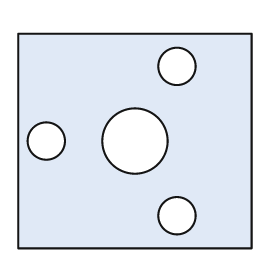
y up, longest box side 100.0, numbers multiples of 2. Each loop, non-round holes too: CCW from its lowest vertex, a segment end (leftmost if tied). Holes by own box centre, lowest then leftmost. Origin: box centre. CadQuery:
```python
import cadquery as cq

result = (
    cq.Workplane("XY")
    .moveTo(-50.0, -46.0)
    .lineTo(50.0, -46.0)
    .lineTo(50.0, 46.0)
    .lineTo(-50.0, 46.0)
    .close()
    .moveTo(18.0, -32.0)
    .circle(8.0)
    .moveTo(-38.0, 0.0)
    .circle(8.0)
    .moveTo(0.0, 0.0)
    .circle(14.0)
    .moveTo(18.0, 32.0)
    .circle(8.0)
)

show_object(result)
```